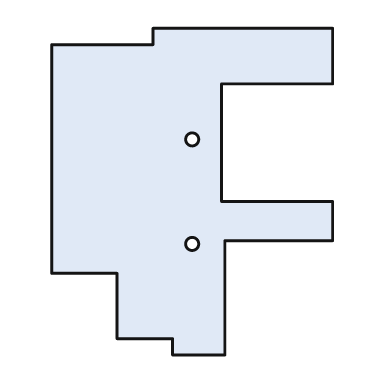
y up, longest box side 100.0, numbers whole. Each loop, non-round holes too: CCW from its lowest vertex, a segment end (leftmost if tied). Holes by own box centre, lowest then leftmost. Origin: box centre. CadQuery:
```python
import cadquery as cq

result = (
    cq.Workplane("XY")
    .moveTo(-6.0, -50.0)
    .lineTo(10.0, -50.0)
    .lineTo(10.0, -15.0)
    .lineTo(43.0, -15.0)
    .lineTo(43.0, -3.0)
    .lineTo(9.0, -3.0)
    .lineTo(9.0, 33.0)
    .lineTo(43.0, 33.0)
    .lineTo(43.0, 50.0)
    .lineTo(-12.0, 50.0)
    .lineTo(-12.0, 45.0)
    .lineTo(-43.0, 45.0)
    .lineTo(-43.0, -25.0)
    .lineTo(-23.0, -25.0)
    .lineTo(-23.0, -45.0)
    .lineTo(-6.0, -45.0)
    .close()
    .moveTo(0.0, -16.0)
    .circle(2.0)
    .moveTo(0.0, 16.0)
    .circle(2.0)
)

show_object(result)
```